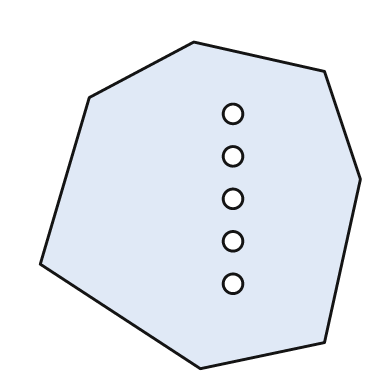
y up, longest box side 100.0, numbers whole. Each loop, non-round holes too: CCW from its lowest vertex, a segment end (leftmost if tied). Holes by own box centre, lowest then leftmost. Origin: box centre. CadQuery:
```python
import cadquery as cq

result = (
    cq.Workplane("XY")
    .moveTo(0.0, -50.0)
    .lineTo(38.0, -42.0)
    .lineTo(49.0, 8.0)
    .lineTo(38.0, 41.0)
    .lineTo(-2.0, 50.0)
    .lineTo(-34.0, 33.0)
    .lineTo(-49.0, -18.0)
    .close()
    .moveTo(10.0, -24.0)
    .circle(3.0)
    .moveTo(10.0, -11.0)
    .circle(3.0)
    .moveTo(10.0, 2.0)
    .circle(3.0)
    .moveTo(10.0, 15.0)
    .circle(3.0)
    .moveTo(10.0, 28.0)
    .circle(3.0)
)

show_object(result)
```